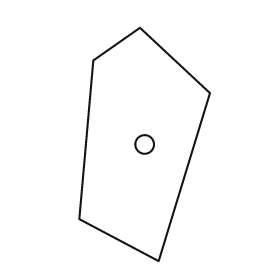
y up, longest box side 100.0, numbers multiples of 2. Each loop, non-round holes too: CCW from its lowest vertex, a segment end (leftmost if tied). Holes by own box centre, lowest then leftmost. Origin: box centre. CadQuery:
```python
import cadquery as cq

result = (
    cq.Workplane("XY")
    .moveTo(6.0, -50.0)
    .lineTo(28.0, 22.0)
    .lineTo(-2.0, 50.0)
    .lineTo(-22.0, 36.0)
    .lineTo(-28.0, -32.0)
    .close()
    .moveTo(0.0, 0.0)
    .circle(4.0)
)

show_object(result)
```